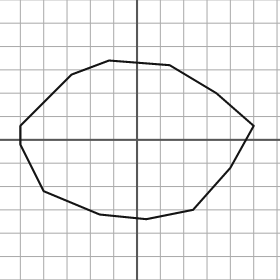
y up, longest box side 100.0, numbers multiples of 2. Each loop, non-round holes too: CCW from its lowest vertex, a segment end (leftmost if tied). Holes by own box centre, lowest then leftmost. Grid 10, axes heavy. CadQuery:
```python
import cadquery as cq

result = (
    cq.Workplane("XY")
    .moveTo(4.0, -34.0)
    .lineTo(24.0, -30.0)
    .lineTo(40.0, -12.0)
    .lineTo(50.0, 6.0)
    .lineTo(34.0, 20.0)
    .lineTo(14.0, 32.0)
    .lineTo(-12.0, 34.0)
    .lineTo(-28.0, 28.0)
    .lineTo(-50.0, 6.0)
    .lineTo(-50.0, -2.0)
    .lineTo(-40.0, -22.0)
    .lineTo(-16.0, -32.0)
    .close()
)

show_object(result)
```